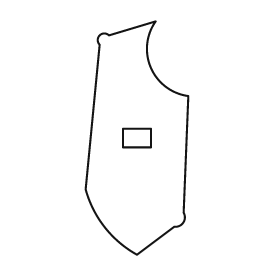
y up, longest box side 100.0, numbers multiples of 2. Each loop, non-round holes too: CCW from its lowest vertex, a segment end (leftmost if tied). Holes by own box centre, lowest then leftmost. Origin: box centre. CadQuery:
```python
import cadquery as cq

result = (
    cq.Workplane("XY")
    .moveTo(0.0, -50.0)
    .lineTo(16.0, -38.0)
    .threePointArc((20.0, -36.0), (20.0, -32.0))
    .lineTo(22.0, 18.0)
    .threePointArc((6.0, 30.0), (8.0, 50.0))
    .lineTo(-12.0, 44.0)
    .threePointArc((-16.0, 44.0), (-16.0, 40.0))
    .lineTo(-22.0, -22.0)
    .threePointArc((-14.0, -38.0), (0.0, -50.0))
    .close()
    .moveTo(-6.0, -4.0)
    .lineTo(6.0, -4.0)
    .lineTo(6.0, 4.0)
    .lineTo(-6.0, 4.0)
    .close()
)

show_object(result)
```